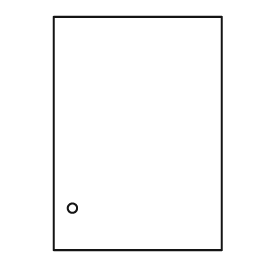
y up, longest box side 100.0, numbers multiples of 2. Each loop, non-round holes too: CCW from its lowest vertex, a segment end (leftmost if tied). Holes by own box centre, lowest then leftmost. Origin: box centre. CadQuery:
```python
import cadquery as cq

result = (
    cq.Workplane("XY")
    .moveTo(-36.0, -50.0)
    .lineTo(36.0, -50.0)
    .lineTo(36.0, 50.0)
    .lineTo(-36.0, 50.0)
    .close()
    .moveTo(-28.0, -32.0)
    .circle(2.0)
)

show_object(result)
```